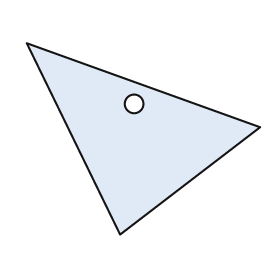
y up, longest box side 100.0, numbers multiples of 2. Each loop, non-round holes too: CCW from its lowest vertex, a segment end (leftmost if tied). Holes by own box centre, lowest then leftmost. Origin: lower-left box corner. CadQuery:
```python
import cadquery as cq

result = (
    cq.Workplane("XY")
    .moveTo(40.0, 0.0)
    .lineTo(100.0, 46.0)
    .lineTo(0.0, 82.0)
    .close()
    .moveTo(46.0, 56.0)
    .circle(4.0)
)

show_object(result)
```